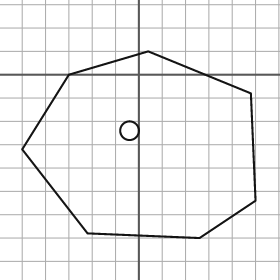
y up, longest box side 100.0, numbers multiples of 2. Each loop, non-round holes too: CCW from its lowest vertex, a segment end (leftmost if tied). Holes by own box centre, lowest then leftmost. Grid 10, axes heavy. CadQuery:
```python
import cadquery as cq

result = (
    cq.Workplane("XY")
    .moveTo(26.0, -70.0)
    .lineTo(50.0, -54.0)
    .lineTo(48.0, -8.0)
    .lineTo(4.0, 10.0)
    .lineTo(-30.0, 0.0)
    .lineTo(-50.0, -32.0)
    .lineTo(-22.0, -68.0)
    .close()
    .moveTo(-4.0, -24.0)
    .circle(4.0)
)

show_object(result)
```